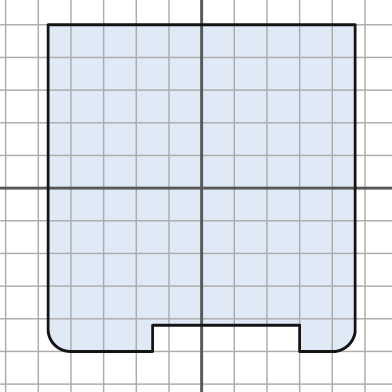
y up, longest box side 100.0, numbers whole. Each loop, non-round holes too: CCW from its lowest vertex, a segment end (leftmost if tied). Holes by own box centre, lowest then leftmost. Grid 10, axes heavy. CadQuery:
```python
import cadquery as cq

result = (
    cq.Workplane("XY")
    .moveTo(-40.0, -50.0)
    .lineTo(-15.0, -50.0)
    .lineTo(-15.0, -42.0)
    .lineTo(30.0, -42.0)
    .lineTo(30.0, -50.0)
    .lineTo(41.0, -50.0)
    .threePointArc((45.0, -48.0), (47.0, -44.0))
    .lineTo(47.0, 50.0)
    .lineTo(-47.0, 50.0)
    .lineTo(-47.0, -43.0)
    .threePointArc((-45.0, -48.0), (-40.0, -50.0))
    .close()
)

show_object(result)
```